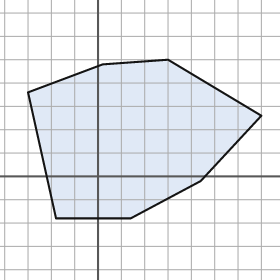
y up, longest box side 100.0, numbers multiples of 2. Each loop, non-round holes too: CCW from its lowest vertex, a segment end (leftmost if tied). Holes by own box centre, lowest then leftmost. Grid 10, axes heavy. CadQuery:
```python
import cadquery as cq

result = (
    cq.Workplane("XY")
    .moveTo(-18.0, -18.0)
    .lineTo(14.0, -18.0)
    .lineTo(44.0, -2.0)
    .lineTo(70.0, 26.0)
    .lineTo(30.0, 50.0)
    .lineTo(2.0, 48.0)
    .lineTo(-30.0, 36.0)
    .close()
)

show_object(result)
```